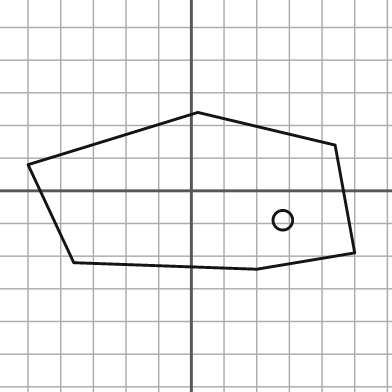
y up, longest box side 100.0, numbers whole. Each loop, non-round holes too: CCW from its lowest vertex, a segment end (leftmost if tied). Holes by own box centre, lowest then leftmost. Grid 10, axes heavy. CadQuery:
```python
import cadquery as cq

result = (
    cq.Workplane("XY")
    .moveTo(20.0, -24.0)
    .lineTo(50.0, -19.0)
    .lineTo(44.0, 14.0)
    .lineTo(2.0, 24.0)
    .lineTo(-50.0, 8.0)
    .lineTo(-36.0, -22.0)
    .close()
    .moveTo(28.0, -9.0)
    .circle(3.0)
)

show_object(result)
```